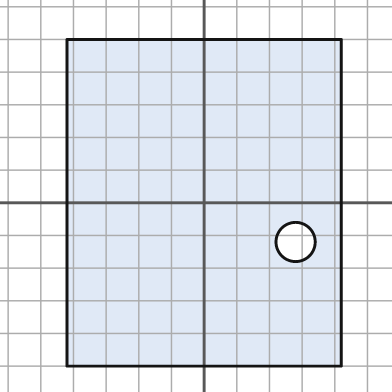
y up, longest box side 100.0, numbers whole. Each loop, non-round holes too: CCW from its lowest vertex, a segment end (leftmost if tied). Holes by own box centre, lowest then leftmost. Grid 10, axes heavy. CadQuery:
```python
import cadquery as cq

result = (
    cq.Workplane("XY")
    .moveTo(-42.0, -50.0)
    .lineTo(42.0, -50.0)
    .lineTo(42.0, 50.0)
    .lineTo(-42.0, 50.0)
    .close()
    .moveTo(28.0, -12.0)
    .circle(6.0)
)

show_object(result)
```